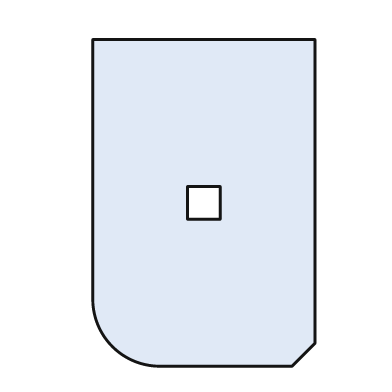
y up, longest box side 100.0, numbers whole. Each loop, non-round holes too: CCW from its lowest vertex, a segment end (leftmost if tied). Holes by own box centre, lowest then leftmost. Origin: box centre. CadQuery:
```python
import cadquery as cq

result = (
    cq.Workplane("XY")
    .moveTo(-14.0, -50.0)
    .lineTo(27.0, -50.0)
    .lineTo(34.0, -43.0)
    .lineTo(34.0, 50.0)
    .lineTo(-34.0, 50.0)
    .lineTo(-34.0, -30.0)
    .threePointArc((-28.0, -44.0), (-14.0, -50.0))
    .close()
    .moveTo(-5.0, -5.0)
    .lineTo(5.0, -5.0)
    .lineTo(5.0, 5.0)
    .lineTo(-5.0, 5.0)
    .close()
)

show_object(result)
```